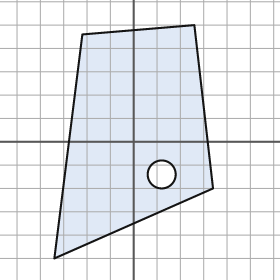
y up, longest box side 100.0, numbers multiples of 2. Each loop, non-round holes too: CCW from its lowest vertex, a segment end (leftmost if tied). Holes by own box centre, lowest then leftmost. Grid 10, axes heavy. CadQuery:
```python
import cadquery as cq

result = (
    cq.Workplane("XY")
    .moveTo(-34.0, -50.0)
    .lineTo(34.0, -20.0)
    .lineTo(26.0, 50.0)
    .lineTo(-22.0, 46.0)
    .close()
    .moveTo(12.0, -14.0)
    .circle(6.0)
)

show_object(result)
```